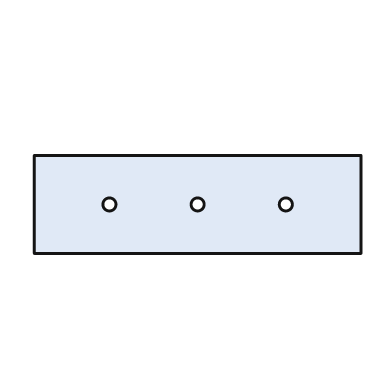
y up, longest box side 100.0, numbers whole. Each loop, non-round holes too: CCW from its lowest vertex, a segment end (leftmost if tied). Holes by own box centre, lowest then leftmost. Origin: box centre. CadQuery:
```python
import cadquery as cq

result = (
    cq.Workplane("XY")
    .moveTo(-50.0, -15.0)
    .lineTo(50.0, -15.0)
    .lineTo(50.0, 15.0)
    .lineTo(-50.0, 15.0)
    .close()
    .moveTo(-27.0, 0.0)
    .circle(2.0)
    .moveTo(0.0, 0.0)
    .circle(2.0)
    .moveTo(27.0, 0.0)
    .circle(2.0)
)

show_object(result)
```